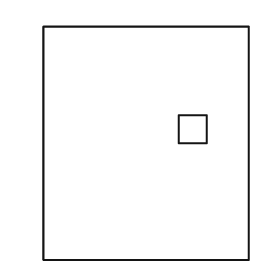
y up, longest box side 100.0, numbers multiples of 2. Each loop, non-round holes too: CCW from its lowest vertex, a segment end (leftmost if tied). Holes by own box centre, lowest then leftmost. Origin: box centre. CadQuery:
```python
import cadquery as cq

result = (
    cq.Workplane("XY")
    .moveTo(-44.0, -50.0)
    .lineTo(44.0, -50.0)
    .lineTo(44.0, 50.0)
    .lineTo(-44.0, 50.0)
    .close()
    .moveTo(14.0, 0.0)
    .lineTo(26.0, 0.0)
    .lineTo(26.0, 12.0)
    .lineTo(14.0, 12.0)
    .close()
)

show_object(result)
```